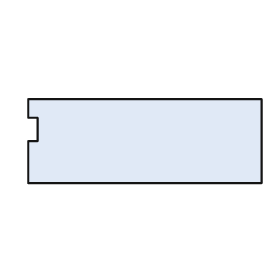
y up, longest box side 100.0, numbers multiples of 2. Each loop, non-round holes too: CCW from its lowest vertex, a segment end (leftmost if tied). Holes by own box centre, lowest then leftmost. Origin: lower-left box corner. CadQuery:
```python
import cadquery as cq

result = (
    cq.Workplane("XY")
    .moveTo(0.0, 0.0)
    .lineTo(100.0, 0.0)
    .lineTo(100.0, 36.0)
    .lineTo(0.0, 36.0)
    .lineTo(0.0, 28.0)
    .lineTo(4.0, 28.0)
    .lineTo(4.0, 18.0)
    .lineTo(0.0, 18.0)
    .close()
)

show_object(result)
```